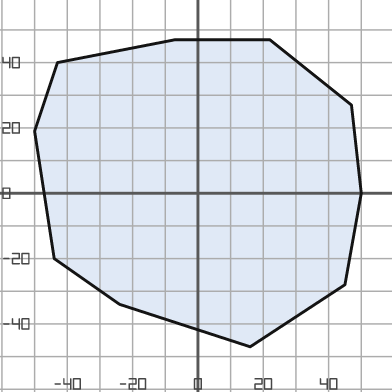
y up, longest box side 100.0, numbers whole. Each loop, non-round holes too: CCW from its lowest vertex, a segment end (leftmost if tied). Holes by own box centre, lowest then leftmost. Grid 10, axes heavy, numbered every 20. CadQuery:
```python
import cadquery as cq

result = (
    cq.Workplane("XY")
    .moveTo(16.0, -47.0)
    .lineTo(45.0, -28.0)
    .lineTo(50.0, 0.0)
    .lineTo(47.0, 27.0)
    .lineTo(22.0, 47.0)
    .lineTo(-7.0, 47.0)
    .lineTo(-43.0, 40.0)
    .lineTo(-50.0, 19.0)
    .lineTo(-44.0, -20.0)
    .lineTo(-24.0, -34.0)
    .close()
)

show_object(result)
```